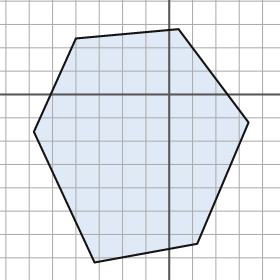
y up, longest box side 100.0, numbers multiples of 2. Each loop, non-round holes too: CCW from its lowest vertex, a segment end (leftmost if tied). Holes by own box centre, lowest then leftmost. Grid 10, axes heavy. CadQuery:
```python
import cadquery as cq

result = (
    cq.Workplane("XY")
    .moveTo(-32.0, -72.0)
    .lineTo(12.0, -64.0)
    .lineTo(34.0, -12.0)
    .lineTo(4.0, 28.0)
    .lineTo(-40.0, 24.0)
    .lineTo(-58.0, -16.0)
    .close()
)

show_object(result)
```